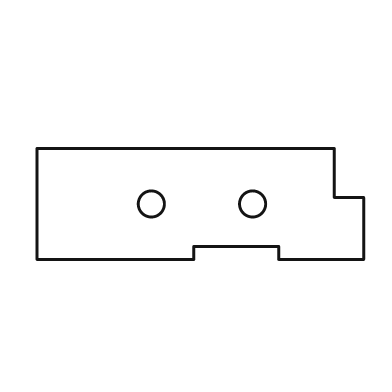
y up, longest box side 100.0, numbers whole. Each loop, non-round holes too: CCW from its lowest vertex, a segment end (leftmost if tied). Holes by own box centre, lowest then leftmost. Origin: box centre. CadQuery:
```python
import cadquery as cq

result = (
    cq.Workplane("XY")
    .moveTo(-50.0, -17.0)
    .lineTo(-2.0, -17.0)
    .lineTo(-2.0, -13.0)
    .lineTo(24.0, -13.0)
    .lineTo(24.0, -17.0)
    .lineTo(50.0, -17.0)
    .lineTo(50.0, 2.0)
    .lineTo(41.0, 2.0)
    .lineTo(41.0, 17.0)
    .lineTo(-50.0, 17.0)
    .close()
    .moveTo(-15.0, 0.0)
    .circle(4.0)
    .moveTo(16.0, 0.0)
    .circle(4.0)
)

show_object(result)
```